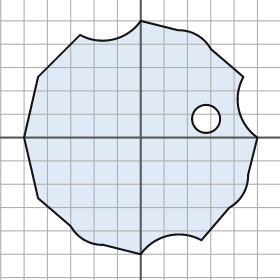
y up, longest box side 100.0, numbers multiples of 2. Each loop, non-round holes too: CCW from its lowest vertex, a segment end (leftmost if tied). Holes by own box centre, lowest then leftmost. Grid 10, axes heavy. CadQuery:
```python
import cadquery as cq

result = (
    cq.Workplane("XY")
    .moveTo(0.0, -50.0)
    .threePointArc((12.0, -42.0), (26.0, -44.0))
    .lineTo(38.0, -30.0)
    .threePointArc((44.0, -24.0), (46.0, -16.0))
    .lineTo(50.0, 0.0)
    .threePointArc((42.0, 12.0), (44.0, 26.0))
    .lineTo(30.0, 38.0)
    .threePointArc((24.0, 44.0), (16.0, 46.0))
    .lineTo(0.0, 50.0)
    .threePointArc((-12.0, 42.0), (-26.0, 44.0))
    .lineTo(-44.0, 26.0)
    .lineTo(-50.0, 0.0)
    .lineTo(-44.0, -26.0)
    .lineTo(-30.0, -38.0)
    .threePointArc((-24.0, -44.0), (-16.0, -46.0))
    .close()
    .moveTo(28.0, 8.0)
    .circle(6.0)
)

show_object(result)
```